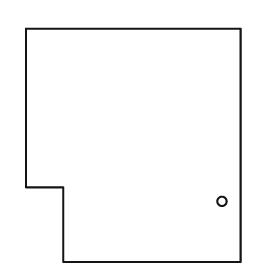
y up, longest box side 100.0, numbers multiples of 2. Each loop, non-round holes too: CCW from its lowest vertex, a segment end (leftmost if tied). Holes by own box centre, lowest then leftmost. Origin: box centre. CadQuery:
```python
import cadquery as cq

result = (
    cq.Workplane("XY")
    .moveTo(-30.0, -50.0)
    .lineTo(46.0, -50.0)
    .lineTo(46.0, 50.0)
    .lineTo(-46.0, 50.0)
    .lineTo(-46.0, -18.0)
    .lineTo(-30.0, -18.0)
    .close()
    .moveTo(38.0, -24.0)
    .circle(2.0)
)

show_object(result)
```